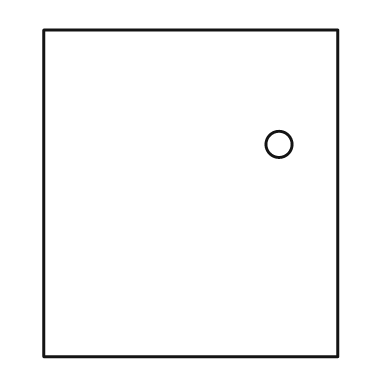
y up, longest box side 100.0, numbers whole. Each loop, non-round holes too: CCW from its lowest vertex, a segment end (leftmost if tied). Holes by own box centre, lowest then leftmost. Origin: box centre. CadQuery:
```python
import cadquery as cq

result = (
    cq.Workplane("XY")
    .moveTo(-45.0, -50.0)
    .lineTo(45.0, -50.0)
    .lineTo(45.0, 50.0)
    .lineTo(-45.0, 50.0)
    .close()
    .moveTo(27.0, 15.0)
    .circle(4.0)
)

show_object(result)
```